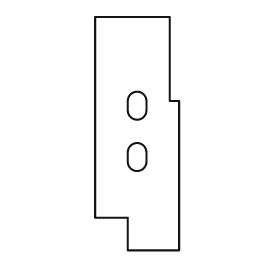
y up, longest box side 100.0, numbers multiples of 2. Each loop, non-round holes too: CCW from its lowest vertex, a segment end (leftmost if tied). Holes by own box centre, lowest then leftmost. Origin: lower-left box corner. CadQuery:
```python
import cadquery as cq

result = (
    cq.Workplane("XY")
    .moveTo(14.0, 0.0)
    .lineTo(36.0, 0.0)
    .lineTo(36.0, 64.0)
    .lineTo(32.0, 64.0)
    .lineTo(32.0, 100.0)
    .lineTo(0.0, 100.0)
    .lineTo(0.0, 14.0)
    .lineTo(14.0, 14.0)
    .close()
    .moveTo(14.0, 38.0)
    .threePointArc((18.0, 34.0), (22.0, 38.0))
    .lineTo(22.0, 42.0)
    .threePointArc((18.0, 46.0), (14.0, 42.0))
    .close()
    .moveTo(14.0, 60.0)
    .threePointArc((18.0, 56.0), (22.0, 60.0))
    .lineTo(22.0, 64.0)
    .threePointArc((18.0, 68.0), (14.0, 64.0))
    .close()
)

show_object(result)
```